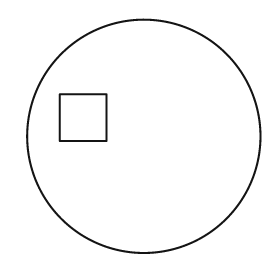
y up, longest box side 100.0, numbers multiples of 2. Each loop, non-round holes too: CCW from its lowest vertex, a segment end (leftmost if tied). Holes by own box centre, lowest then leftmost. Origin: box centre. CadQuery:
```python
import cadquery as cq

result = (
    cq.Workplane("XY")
    .moveTo(0.0, 0.0)
    .circle(50.0)
    .moveTo(-36.0, -2.0)
    .lineTo(-16.0, -2.0)
    .lineTo(-16.0, 18.0)
    .lineTo(-36.0, 18.0)
    .close()
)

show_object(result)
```